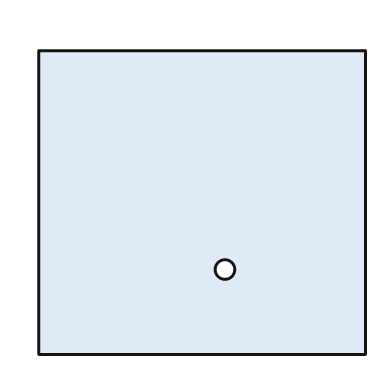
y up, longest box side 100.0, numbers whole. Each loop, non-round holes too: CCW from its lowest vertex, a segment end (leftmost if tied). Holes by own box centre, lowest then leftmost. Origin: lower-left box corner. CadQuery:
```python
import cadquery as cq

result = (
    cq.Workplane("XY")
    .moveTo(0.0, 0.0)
    .lineTo(100.0, 0.0)
    .lineTo(100.0, 93.0)
    .lineTo(0.0, 93.0)
    .close()
    .moveTo(57.0, 26.0)
    .circle(3.0)
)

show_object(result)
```